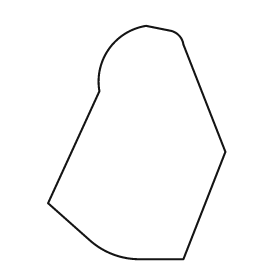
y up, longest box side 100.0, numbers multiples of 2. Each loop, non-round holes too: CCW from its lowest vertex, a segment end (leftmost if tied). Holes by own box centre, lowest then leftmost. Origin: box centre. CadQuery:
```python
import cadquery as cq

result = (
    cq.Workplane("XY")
    .moveTo(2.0, -50.0)
    .lineTo(20.0, -50.0)
    .lineTo(38.0, -4.0)
    .lineTo(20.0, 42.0)
    .threePointArc((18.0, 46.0), (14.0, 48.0))
    .lineTo(4.0, 50.0)
    .threePointArc((-12.0, 40.0), (-16.0, 22.0))
    .lineTo(-38.0, -26.0)
    .lineTo(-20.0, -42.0)
    .threePointArc((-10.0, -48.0), (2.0, -50.0))
    .close()
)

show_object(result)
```